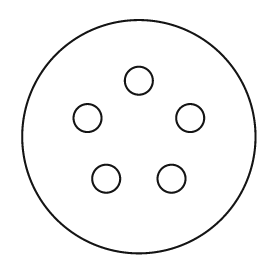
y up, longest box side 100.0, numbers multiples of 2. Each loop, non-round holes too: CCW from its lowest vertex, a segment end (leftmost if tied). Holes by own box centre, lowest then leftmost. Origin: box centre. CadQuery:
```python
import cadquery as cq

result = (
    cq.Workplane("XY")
    .moveTo(0.0, 0.0)
    .circle(50.0)
    .moveTo(-14.0, -18.0)
    .circle(6.0)
    .moveTo(14.0, -18.0)
    .circle(6.0)
    .moveTo(-22.0, 8.0)
    .circle(6.0)
    .moveTo(22.0, 8.0)
    .circle(6.0)
    .moveTo(0.0, 24.0)
    .circle(6.0)
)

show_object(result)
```